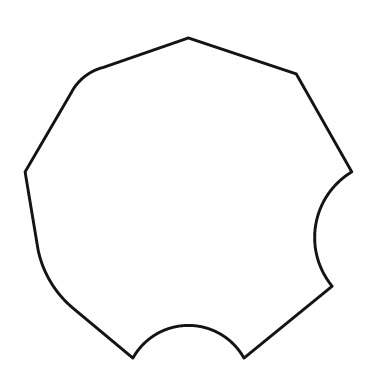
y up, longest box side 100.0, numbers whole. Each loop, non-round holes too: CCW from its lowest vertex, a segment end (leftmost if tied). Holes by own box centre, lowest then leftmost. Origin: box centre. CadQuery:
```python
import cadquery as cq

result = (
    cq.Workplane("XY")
    .moveTo(-17.0, -49.0)
    .threePointArc((0.0, -39.0), (17.0, -49.0))
    .lineTo(44.0, -27.0)
    .threePointArc((39.0, -8.0), (50.0, 8.0))
    .lineTo(33.0, 38.0)
    .lineTo(0.0, 49.0)
    .lineTo(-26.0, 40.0)
    .threePointArc((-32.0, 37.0), (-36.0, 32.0))
    .lineTo(-50.0, 8.0)
    .lineTo(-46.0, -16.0)
    .threePointArc((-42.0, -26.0), (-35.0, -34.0))
    .close()
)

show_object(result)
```